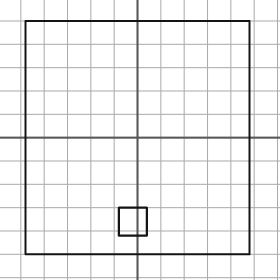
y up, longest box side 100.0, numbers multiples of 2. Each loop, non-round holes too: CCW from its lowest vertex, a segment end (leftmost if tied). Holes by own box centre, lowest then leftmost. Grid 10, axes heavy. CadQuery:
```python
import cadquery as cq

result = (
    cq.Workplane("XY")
    .moveTo(-48.0, -50.0)
    .lineTo(48.0, -50.0)
    .lineTo(48.0, 50.0)
    .lineTo(-48.0, 50.0)
    .close()
    .moveTo(-8.0, -42.0)
    .lineTo(4.0, -42.0)
    .lineTo(4.0, -30.0)
    .lineTo(-8.0, -30.0)
    .close()
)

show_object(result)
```